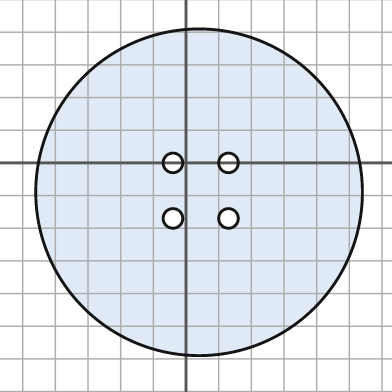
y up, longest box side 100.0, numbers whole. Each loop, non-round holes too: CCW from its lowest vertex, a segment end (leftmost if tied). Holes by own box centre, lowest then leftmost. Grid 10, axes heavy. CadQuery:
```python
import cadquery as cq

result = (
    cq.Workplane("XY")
    .moveTo(4.0, -9.0)
    .circle(50.0)
    .moveTo(-4.0, -17.0)
    .circle(3.0)
    .moveTo(13.0, -17.0)
    .circle(3.0)
    .moveTo(-4.0, 0.0)
    .circle(3.0)
    .moveTo(13.0, 0.0)
    .circle(3.0)
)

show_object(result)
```